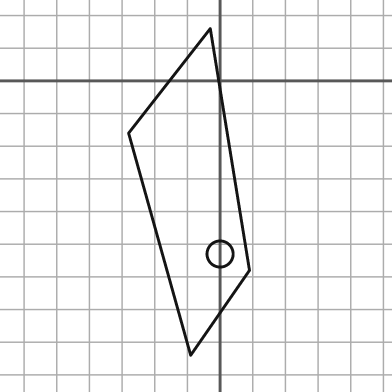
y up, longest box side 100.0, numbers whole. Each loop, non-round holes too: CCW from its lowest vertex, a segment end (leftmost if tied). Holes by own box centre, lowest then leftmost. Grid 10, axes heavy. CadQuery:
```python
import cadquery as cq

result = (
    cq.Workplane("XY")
    .moveTo(-9.0, -84.0)
    .lineTo(9.0, -58.0)
    .lineTo(-3.0, 16.0)
    .lineTo(-28.0, -16.0)
    .close()
    .moveTo(0.0, -53.0)
    .circle(4.0)
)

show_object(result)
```